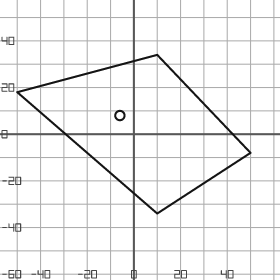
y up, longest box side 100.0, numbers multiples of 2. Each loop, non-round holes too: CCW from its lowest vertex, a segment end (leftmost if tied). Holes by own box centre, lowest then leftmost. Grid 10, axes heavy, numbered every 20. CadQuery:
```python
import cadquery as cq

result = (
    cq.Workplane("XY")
    .moveTo(10.0, -34.0)
    .lineTo(50.0, -8.0)
    .lineTo(10.0, 34.0)
    .lineTo(-50.0, 18.0)
    .close()
    .moveTo(-6.0, 8.0)
    .circle(2.0)
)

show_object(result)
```